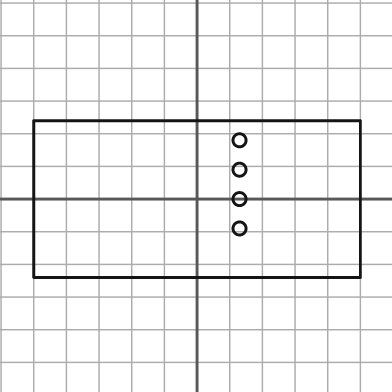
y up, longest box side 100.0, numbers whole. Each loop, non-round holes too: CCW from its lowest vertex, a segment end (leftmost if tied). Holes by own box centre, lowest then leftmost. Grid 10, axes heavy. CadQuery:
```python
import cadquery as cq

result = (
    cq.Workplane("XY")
    .moveTo(-50.0, -24.0)
    .lineTo(50.0, -24.0)
    .lineTo(50.0, 24.0)
    .lineTo(-50.0, 24.0)
    .close()
    .moveTo(13.0, -9.0)
    .circle(2.0)
    .moveTo(13.0, 0.0)
    .circle(2.0)
    .moveTo(13.0, 9.0)
    .circle(2.0)
    .moveTo(13.0, 18.0)
    .circle(2.0)
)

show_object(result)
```